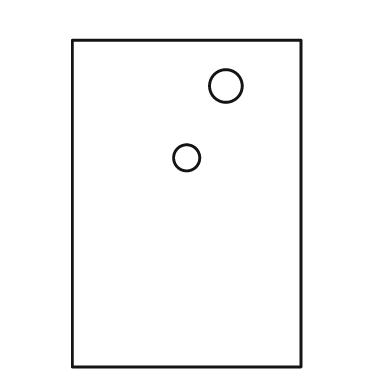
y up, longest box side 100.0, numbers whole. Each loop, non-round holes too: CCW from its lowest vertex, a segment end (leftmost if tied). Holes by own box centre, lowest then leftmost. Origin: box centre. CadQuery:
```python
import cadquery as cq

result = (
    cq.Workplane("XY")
    .moveTo(-35.0, -50.0)
    .lineTo(35.0, -50.0)
    .lineTo(35.0, 50.0)
    .lineTo(-35.0, 50.0)
    .close()
    .moveTo(0.0, 14.0)
    .circle(4.0)
    .moveTo(12.0, 36.0)
    .circle(5.0)
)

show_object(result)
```